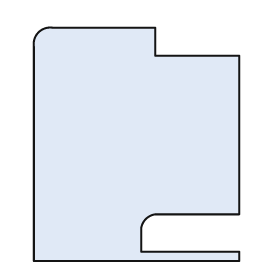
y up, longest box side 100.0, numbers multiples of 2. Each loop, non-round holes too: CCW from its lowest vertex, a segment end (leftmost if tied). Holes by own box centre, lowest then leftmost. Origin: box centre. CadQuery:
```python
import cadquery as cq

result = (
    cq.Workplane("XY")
    .moveTo(-44.0, -50.0)
    .lineTo(44.0, -50.0)
    .lineTo(44.0, -46.0)
    .lineTo(2.0, -46.0)
    .lineTo(2.0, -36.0)
    .threePointArc((4.0, -32.0), (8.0, -30.0))
    .lineTo(44.0, -30.0)
    .lineTo(44.0, 38.0)
    .lineTo(8.0, 38.0)
    .lineTo(8.0, 50.0)
    .lineTo(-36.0, 50.0)
    .threePointArc((-42.0, 48.0), (-44.0, 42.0))
    .close()
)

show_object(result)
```